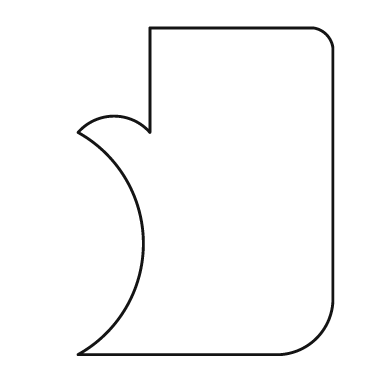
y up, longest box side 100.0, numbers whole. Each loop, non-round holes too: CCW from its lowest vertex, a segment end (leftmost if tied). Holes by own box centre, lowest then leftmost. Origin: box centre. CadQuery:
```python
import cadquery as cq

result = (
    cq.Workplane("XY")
    .moveTo(-39.0, -50.0)
    .lineTo(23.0, -50.0)
    .threePointArc((34.0, -45.0), (39.0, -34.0))
    .lineTo(39.0, 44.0)
    .threePointArc((37.0, 48.0), (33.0, 50.0))
    .lineTo(-17.0, 50.0)
    .lineTo(-17.0, 18.0)
    .threePointArc((-28.0, 23.0), (-39.0, 18.0))
    .threePointArc((-19.0, -16.0), (-39.0, -50.0))
    .close()
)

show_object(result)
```